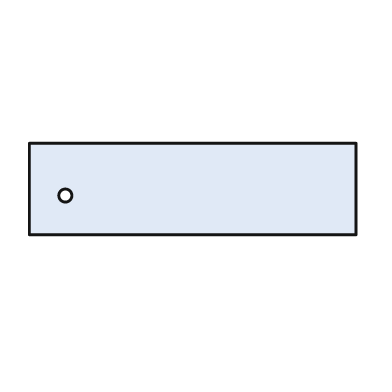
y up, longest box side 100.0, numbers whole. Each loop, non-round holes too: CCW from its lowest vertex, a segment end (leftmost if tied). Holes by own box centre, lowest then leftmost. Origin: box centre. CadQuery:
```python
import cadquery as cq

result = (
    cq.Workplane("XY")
    .moveTo(-50.0, -14.0)
    .lineTo(50.0, -14.0)
    .lineTo(50.0, 14.0)
    .lineTo(-50.0, 14.0)
    .close()
    .moveTo(-39.0, -2.0)
    .circle(2.0)
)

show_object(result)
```